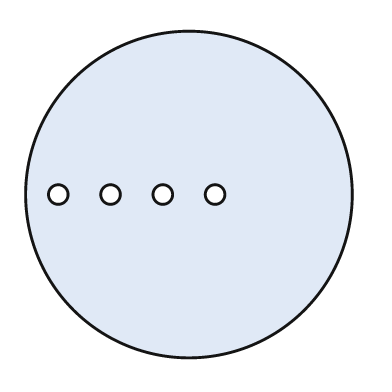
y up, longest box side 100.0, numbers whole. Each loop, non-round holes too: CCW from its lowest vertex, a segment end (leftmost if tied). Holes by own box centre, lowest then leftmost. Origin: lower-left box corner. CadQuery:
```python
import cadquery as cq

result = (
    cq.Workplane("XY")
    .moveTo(50.0, 50.0)
    .circle(50.0)
    .moveTo(10.0, 50.0)
    .circle(3.0)
    .moveTo(26.0, 50.0)
    .circle(3.0)
    .moveTo(42.0, 50.0)
    .circle(3.0)
    .moveTo(58.0, 50.0)
    .circle(3.0)
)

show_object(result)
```